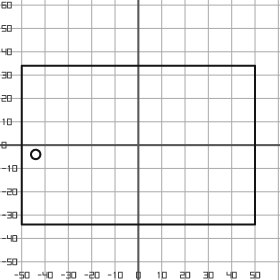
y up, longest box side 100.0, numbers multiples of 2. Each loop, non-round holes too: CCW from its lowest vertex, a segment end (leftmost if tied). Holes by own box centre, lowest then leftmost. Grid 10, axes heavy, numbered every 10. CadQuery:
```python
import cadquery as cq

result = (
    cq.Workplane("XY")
    .moveTo(-50.0, -34.0)
    .lineTo(50.0, -34.0)
    .lineTo(50.0, 34.0)
    .lineTo(-50.0, 34.0)
    .close()
    .moveTo(-44.0, -4.0)
    .circle(2.0)
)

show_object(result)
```